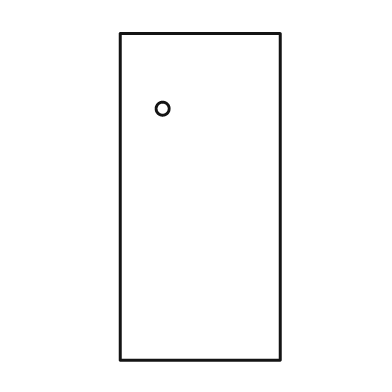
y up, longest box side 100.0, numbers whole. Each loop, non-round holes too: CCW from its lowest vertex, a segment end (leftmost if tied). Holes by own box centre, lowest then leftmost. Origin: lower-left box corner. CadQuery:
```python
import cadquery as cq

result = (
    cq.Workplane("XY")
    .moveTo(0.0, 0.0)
    .lineTo(49.0, 0.0)
    .lineTo(49.0, 100.0)
    .lineTo(0.0, 100.0)
    .close()
    .moveTo(13.0, 77.0)
    .circle(2.0)
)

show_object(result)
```